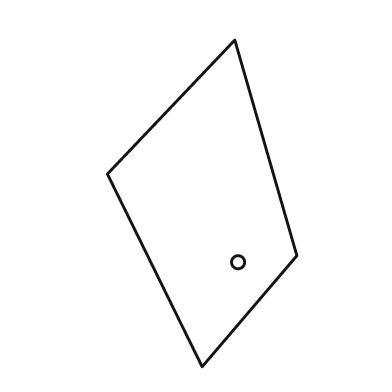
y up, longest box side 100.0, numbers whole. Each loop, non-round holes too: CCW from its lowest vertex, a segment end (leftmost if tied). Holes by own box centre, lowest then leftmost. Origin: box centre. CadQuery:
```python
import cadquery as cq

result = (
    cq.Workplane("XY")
    .moveTo(0.0, -50.0)
    .lineTo(29.0, -16.0)
    .lineTo(10.0, 50.0)
    .lineTo(-29.0, 9.0)
    .close()
    .moveTo(11.0, -18.0)
    .circle(2.0)
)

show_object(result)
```